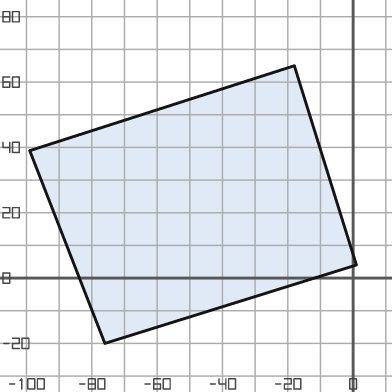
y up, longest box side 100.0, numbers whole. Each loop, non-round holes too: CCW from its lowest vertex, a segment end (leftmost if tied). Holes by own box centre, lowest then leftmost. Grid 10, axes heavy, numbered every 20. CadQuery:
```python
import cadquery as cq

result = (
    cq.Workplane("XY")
    .moveTo(-76.0, -20.0)
    .lineTo(1.0, 4.0)
    .lineTo(-18.0, 65.0)
    .lineTo(-99.0, 39.0)
    .close()
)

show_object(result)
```